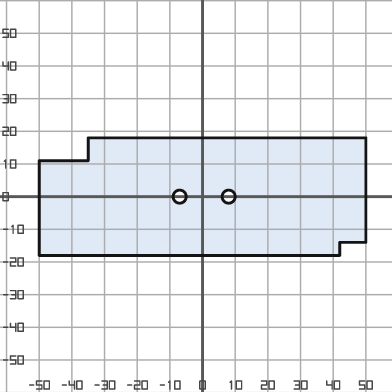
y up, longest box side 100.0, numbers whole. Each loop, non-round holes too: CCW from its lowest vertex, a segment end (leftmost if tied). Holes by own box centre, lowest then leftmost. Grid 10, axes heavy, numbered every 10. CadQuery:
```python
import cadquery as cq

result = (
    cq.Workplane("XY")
    .moveTo(-50.0, -18.0)
    .lineTo(42.0, -18.0)
    .lineTo(42.0, -14.0)
    .lineTo(50.0, -14.0)
    .lineTo(50.0, 18.0)
    .lineTo(-35.0, 18.0)
    .lineTo(-35.0, 11.0)
    .lineTo(-50.0, 11.0)
    .close()
    .moveTo(-7.0, 0.0)
    .circle(2.0)
    .moveTo(8.0, 0.0)
    .circle(2.0)
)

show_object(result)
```